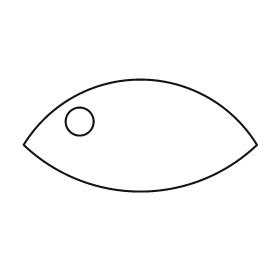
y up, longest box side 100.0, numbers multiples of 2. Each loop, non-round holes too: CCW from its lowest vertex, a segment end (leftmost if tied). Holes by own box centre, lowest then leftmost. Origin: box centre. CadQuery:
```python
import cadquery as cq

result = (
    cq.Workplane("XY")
    .moveTo(-50.0, -4.0)
    .threePointArc((0.0, -24.0), (50.0, -4.0))
    .threePointArc((0.0, 24.0), (-50.0, -4.0))
    .close()
    .moveTo(-26.0, 6.0)
    .circle(6.0)
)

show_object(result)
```